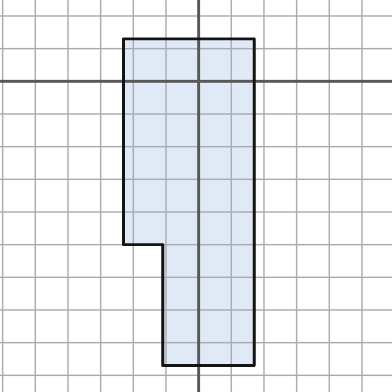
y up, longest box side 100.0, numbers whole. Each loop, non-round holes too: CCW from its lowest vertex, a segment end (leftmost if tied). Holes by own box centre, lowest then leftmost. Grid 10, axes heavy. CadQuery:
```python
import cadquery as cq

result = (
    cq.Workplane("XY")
    .moveTo(-11.0, -87.0)
    .lineTo(17.0, -87.0)
    .lineTo(17.0, 13.0)
    .lineTo(-23.0, 13.0)
    .lineTo(-23.0, -50.0)
    .lineTo(-11.0, -50.0)
    .close()
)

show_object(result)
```